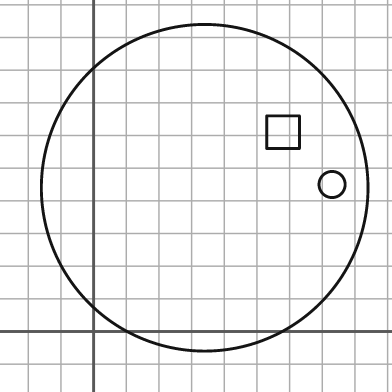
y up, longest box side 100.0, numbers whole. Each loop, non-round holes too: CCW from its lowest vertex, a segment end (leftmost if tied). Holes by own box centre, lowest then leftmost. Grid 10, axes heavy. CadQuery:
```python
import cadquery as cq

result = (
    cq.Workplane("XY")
    .moveTo(34.0, 44.0)
    .circle(50.0)
    .moveTo(73.0, 45.0)
    .circle(4.0)
    .moveTo(53.0, 56.0)
    .lineTo(63.0, 56.0)
    .lineTo(63.0, 66.0)
    .lineTo(53.0, 66.0)
    .close()
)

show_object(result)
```